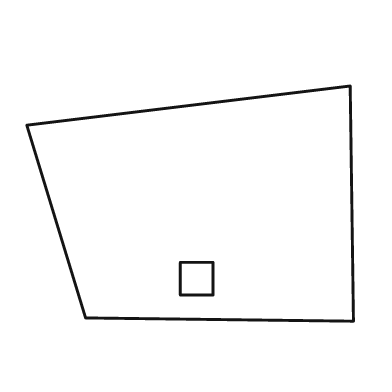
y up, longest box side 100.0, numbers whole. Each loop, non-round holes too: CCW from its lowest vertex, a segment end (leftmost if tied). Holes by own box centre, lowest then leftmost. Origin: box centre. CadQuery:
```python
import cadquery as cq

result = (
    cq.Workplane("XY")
    .moveTo(50.0, -36.0)
    .lineTo(49.0, 36.0)
    .lineTo(-50.0, 24.0)
    .lineTo(-32.0, -35.0)
    .close()
    .moveTo(-3.0, -28.0)
    .lineTo(7.0, -28.0)
    .lineTo(7.0, -18.0)
    .lineTo(-3.0, -18.0)
    .close()
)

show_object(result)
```